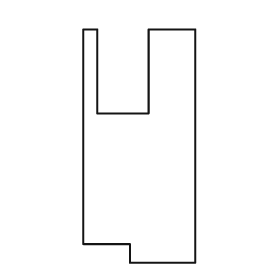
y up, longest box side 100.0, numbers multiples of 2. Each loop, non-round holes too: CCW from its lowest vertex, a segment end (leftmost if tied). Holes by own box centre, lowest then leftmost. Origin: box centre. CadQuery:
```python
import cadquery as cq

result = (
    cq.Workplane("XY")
    .moveTo(-4.0, -50.0)
    .lineTo(24.0, -50.0)
    .lineTo(24.0, 50.0)
    .lineTo(4.0, 50.0)
    .lineTo(4.0, 14.0)
    .lineTo(-18.0, 14.0)
    .lineTo(-18.0, 50.0)
    .lineTo(-24.0, 50.0)
    .lineTo(-24.0, -42.0)
    .lineTo(-4.0, -42.0)
    .close()
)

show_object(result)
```